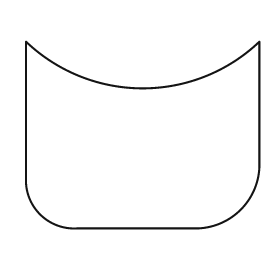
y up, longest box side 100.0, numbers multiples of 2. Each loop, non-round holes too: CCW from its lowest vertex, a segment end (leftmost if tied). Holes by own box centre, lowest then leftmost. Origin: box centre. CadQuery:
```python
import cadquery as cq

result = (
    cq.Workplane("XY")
    .moveTo(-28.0, -40.0)
    .lineTo(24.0, -40.0)
    .threePointArc((42.0, -32.0), (50.0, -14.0))
    .lineTo(50.0, 40.0)
    .threePointArc((0.0, 20.0), (-50.0, 40.0))
    .lineTo(-50.0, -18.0)
    .threePointArc((-44.0, -34.0), (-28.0, -40.0))
    .close()
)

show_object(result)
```